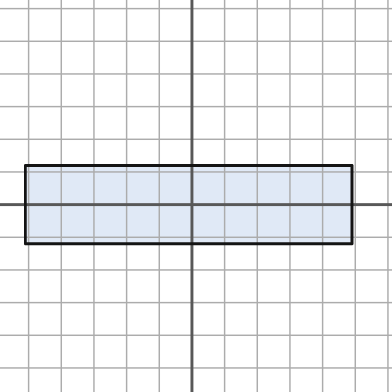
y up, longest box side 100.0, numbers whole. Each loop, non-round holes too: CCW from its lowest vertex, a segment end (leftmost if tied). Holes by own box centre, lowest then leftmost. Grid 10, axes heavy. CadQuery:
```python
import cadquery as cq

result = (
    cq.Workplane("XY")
    .moveTo(-51.0, -12.0)
    .lineTo(49.0, -12.0)
    .lineTo(49.0, 12.0)
    .lineTo(-51.0, 12.0)
    .close()
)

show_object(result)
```